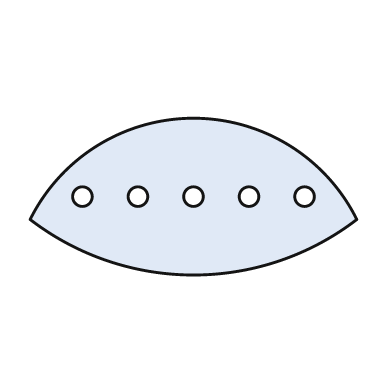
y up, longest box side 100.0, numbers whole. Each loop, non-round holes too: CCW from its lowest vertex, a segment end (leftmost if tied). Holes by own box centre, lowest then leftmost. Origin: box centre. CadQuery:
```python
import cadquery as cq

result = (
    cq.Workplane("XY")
    .moveTo(-50.0, -7.0)
    .threePointArc((0.0, -24.0), (50.0, -7.0))
    .threePointArc((0.0, 24.0), (-50.0, -7.0))
    .close()
    .moveTo(-34.0, 0.0)
    .circle(3.0)
    .moveTo(-17.0, 0.0)
    .circle(3.0)
    .moveTo(0.0, 0.0)
    .circle(3.0)
    .moveTo(17.0, 0.0)
    .circle(3.0)
    .moveTo(34.0, 0.0)
    .circle(3.0)
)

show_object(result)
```